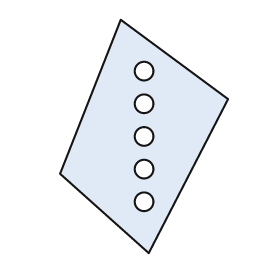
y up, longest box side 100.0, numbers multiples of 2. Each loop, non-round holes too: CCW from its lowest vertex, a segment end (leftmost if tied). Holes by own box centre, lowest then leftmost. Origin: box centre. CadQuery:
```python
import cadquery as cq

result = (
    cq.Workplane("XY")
    .moveTo(2.0, -50.0)
    .lineTo(36.0, 16.0)
    .lineTo(-10.0, 50.0)
    .lineTo(-36.0, -16.0)
    .close()
    .moveTo(0.0, -28.0)
    .circle(4.0)
    .moveTo(0.0, -14.0)
    .circle(4.0)
    .moveTo(0.0, 0.0)
    .circle(4.0)
    .moveTo(0.0, 14.0)
    .circle(4.0)
    .moveTo(0.0, 28.0)
    .circle(4.0)
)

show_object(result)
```